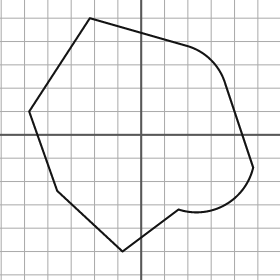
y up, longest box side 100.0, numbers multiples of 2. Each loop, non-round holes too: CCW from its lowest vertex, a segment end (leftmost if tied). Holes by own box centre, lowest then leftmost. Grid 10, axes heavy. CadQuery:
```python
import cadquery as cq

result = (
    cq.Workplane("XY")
    .moveTo(-8.0, -50.0)
    .lineTo(16.0, -32.0)
    .threePointArc((36.0, -30.0), (48.0, -14.0))
    .lineTo(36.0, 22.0)
    .threePointArc((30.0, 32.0), (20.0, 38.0))
    .lineTo(-22.0, 50.0)
    .lineTo(-48.0, 10.0)
    .lineTo(-36.0, -24.0)
    .close()
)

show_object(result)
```